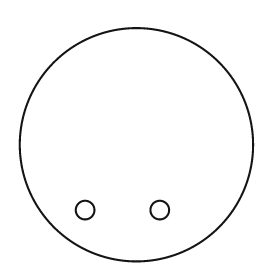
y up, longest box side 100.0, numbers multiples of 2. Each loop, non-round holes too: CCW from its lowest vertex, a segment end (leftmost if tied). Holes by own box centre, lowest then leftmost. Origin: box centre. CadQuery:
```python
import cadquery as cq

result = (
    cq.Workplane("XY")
    .moveTo(0.0, 0.0)
    .circle(50.0)
    .moveTo(-22.0, -28.0)
    .circle(4.0)
    .moveTo(10.0, -28.0)
    .circle(4.0)
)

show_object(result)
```